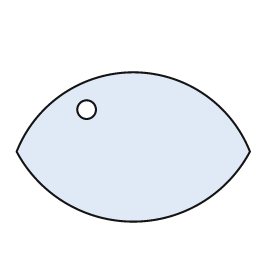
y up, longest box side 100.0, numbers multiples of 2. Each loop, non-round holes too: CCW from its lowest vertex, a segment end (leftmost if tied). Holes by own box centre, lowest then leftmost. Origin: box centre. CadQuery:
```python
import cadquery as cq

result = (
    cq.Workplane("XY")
    .moveTo(-50.0, -2.0)
    .threePointArc((0.0, -32.0), (50.0, -2.0))
    .threePointArc((0.0, 32.0), (-50.0, -2.0))
    .close()
    .moveTo(-20.0, 16.0)
    .circle(4.0)
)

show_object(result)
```